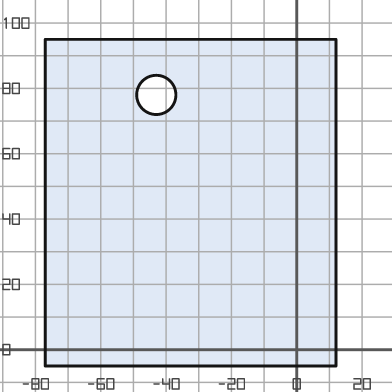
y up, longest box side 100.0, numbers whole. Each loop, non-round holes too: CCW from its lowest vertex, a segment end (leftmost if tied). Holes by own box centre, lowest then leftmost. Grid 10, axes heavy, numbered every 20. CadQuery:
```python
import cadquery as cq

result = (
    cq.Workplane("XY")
    .moveTo(-77.0, -5.0)
    .lineTo(12.0, -5.0)
    .lineTo(12.0, 95.0)
    .lineTo(-77.0, 95.0)
    .close()
    .moveTo(-43.0, 78.0)
    .circle(6.0)
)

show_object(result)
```